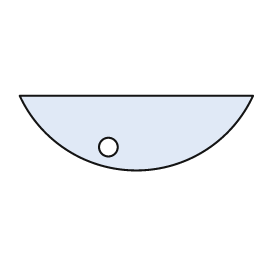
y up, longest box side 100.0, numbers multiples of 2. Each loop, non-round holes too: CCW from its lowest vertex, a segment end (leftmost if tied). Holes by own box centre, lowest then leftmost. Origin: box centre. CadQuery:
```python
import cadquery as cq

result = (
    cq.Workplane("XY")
    .moveTo(-50.0, 16.0)
    .threePointArc((0.0, -16.0), (50.0, 16.0))
    .close()
    .moveTo(-12.0, -6.0)
    .circle(4.0)
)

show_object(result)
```